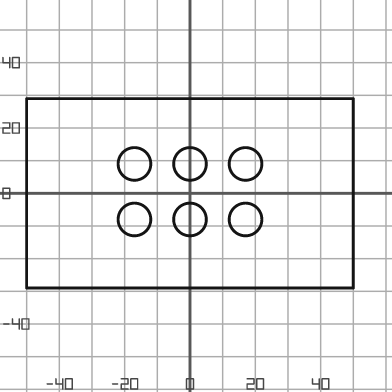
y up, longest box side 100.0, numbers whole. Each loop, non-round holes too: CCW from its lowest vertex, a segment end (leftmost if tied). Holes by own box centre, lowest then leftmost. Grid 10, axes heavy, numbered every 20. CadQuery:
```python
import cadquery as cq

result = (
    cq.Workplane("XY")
    .moveTo(-50.0, -29.0)
    .lineTo(50.0, -29.0)
    .lineTo(50.0, 29.0)
    .lineTo(-50.0, 29.0)
    .close()
    .moveTo(-17.0, -8.0)
    .circle(5.0)
    .moveTo(0.0, -8.0)
    .circle(5.0)
    .moveTo(17.0, -8.0)
    .circle(5.0)
    .moveTo(-17.0, 9.0)
    .circle(5.0)
    .moveTo(0.0, 9.0)
    .circle(5.0)
    .moveTo(17.0, 9.0)
    .circle(5.0)
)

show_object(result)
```